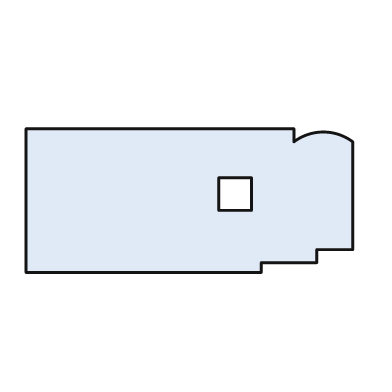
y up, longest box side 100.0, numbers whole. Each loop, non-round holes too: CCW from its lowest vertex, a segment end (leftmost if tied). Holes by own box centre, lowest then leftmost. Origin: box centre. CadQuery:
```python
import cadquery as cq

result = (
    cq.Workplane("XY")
    .moveTo(-50.0, -22.0)
    .lineTo(22.0, -22.0)
    .lineTo(22.0, -19.0)
    .lineTo(39.0, -19.0)
    .lineTo(39.0, -15.0)
    .lineTo(50.0, -15.0)
    .lineTo(50.0, 18.0)
    .threePointArc((41.0, 21.0), (32.0, 18.0))
    .lineTo(32.0, 22.0)
    .lineTo(-50.0, 22.0)
    .close()
    .moveTo(9.0, -3.0)
    .lineTo(19.0, -3.0)
    .lineTo(19.0, 7.0)
    .lineTo(9.0, 7.0)
    .close()
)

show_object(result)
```